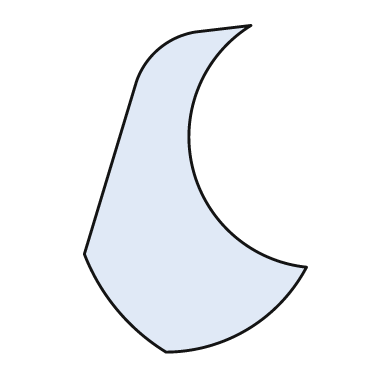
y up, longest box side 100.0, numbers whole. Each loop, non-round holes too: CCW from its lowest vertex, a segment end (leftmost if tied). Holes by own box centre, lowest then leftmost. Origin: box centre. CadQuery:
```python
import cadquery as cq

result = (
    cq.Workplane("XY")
    .moveTo(-9.0, -50.0)
    .threePointArc((16.0, -43.0), (34.0, -24.0))
    .threePointArc((-1.0, 7.0), (17.0, 50.0))
    .lineTo(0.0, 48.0)
    .threePointArc((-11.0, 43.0), (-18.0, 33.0))
    .lineTo(-34.0, -20.0)
    .threePointArc((-24.0, -37.0), (-9.0, -50.0))
    .close()
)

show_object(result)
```